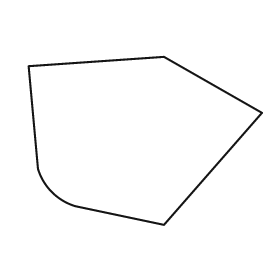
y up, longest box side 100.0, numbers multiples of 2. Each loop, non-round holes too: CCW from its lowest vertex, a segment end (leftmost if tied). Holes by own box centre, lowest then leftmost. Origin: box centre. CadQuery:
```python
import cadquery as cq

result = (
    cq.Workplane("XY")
    .moveTo(8.0, -36.0)
    .lineTo(50.0, 12.0)
    .lineTo(8.0, 36.0)
    .lineTo(-50.0, 32.0)
    .lineTo(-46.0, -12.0)
    .threePointArc((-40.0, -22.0), (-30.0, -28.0))
    .close()
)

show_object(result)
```